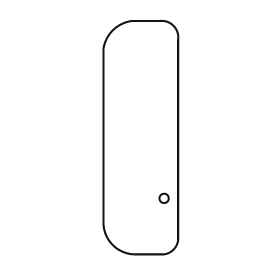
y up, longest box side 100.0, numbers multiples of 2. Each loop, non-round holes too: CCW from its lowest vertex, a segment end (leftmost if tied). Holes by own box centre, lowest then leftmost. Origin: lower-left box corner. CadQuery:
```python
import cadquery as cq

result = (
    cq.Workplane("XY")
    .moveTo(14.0, 0.0)
    .lineTo(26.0, 0.0)
    .threePointArc((30.0, 2.0), (32.0, 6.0))
    .lineTo(32.0, 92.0)
    .threePointArc((30.0, 98.0), (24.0, 100.0))
    .lineTo(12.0, 100.0)
    .threePointArc((4.0, 96.0), (0.0, 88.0))
    .lineTo(0.0, 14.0)
    .threePointArc((4.0, 4.0), (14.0, 0.0))
    .close()
    .moveTo(26.0, 24.0)
    .circle(2.0)
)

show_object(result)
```